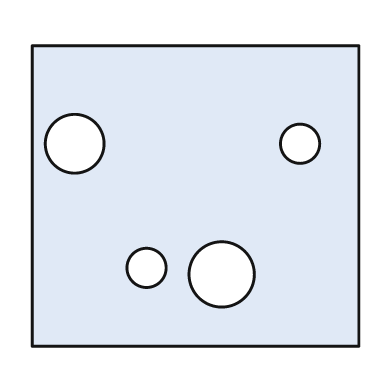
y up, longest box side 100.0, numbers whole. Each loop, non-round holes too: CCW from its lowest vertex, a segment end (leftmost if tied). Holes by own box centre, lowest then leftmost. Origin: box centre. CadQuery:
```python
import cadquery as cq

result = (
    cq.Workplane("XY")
    .moveTo(-50.0, -46.0)
    .lineTo(50.0, -46.0)
    .lineTo(50.0, 46.0)
    .lineTo(-50.0, 46.0)
    .close()
    .moveTo(8.0, -24.0)
    .circle(10.0)
    .moveTo(-15.0, -22.0)
    .circle(6.0)
    .moveTo(-37.0, 16.0)
    .circle(9.0)
    .moveTo(32.0, 16.0)
    .circle(6.0)
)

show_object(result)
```